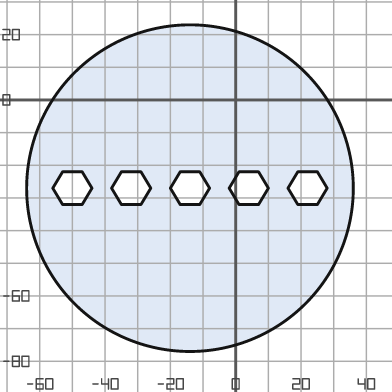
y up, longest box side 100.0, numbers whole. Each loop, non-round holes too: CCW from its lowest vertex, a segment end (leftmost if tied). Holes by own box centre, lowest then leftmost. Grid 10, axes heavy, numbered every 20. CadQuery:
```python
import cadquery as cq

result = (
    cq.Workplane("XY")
    .moveTo(-14.0, -27.0)
    .circle(50.0)
    .moveTo(-53.0, -32.0)
    .lineTo(-47.0, -32.0)
    .lineTo(-44.0, -27.0)
    .lineTo(-47.0, -22.0)
    .lineTo(-53.0, -22.0)
    .lineTo(-56.0, -27.0)
    .close()
    .moveTo(-35.0, -32.0)
    .lineTo(-29.0, -32.0)
    .lineTo(-26.0, -27.0)
    .lineTo(-29.0, -22.0)
    .lineTo(-35.0, -22.0)
    .lineTo(-38.0, -27.0)
    .close()
    .moveTo(-17.0, -32.0)
    .lineTo(-11.0, -32.0)
    .lineTo(-8.0, -27.0)
    .lineTo(-11.0, -22.0)
    .lineTo(-17.0, -22.0)
    .lineTo(-20.0, -27.0)
    .close()
    .moveTo(1.0, -32.0)
    .lineTo(7.0, -32.0)
    .lineTo(10.0, -27.0)
    .lineTo(7.0, -22.0)
    .lineTo(1.0, -22.0)
    .lineTo(-2.0, -27.0)
    .close()
    .moveTo(19.0, -32.0)
    .lineTo(25.0, -32.0)
    .lineTo(28.0, -27.0)
    .lineTo(25.0, -22.0)
    .lineTo(19.0, -22.0)
    .lineTo(16.0, -27.0)
    .close()
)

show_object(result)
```